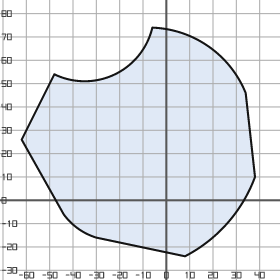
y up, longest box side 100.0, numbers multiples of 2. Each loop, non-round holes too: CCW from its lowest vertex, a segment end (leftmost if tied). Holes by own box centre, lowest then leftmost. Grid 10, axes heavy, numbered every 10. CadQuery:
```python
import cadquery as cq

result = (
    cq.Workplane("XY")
    .moveTo(8.0, -24.0)
    .threePointArc((26.0, -10.0), (38.0, 10.0))
    .lineTo(34.0, 46.0)
    .threePointArc((18.0, 66.0), (-6.0, 74.0))
    .threePointArc((-22.0, 54.0), (-48.0, 54.0))
    .lineTo(-62.0, 26.0)
    .lineTo(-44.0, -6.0)
    .threePointArc((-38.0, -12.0), (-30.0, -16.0))
    .close()
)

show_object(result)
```